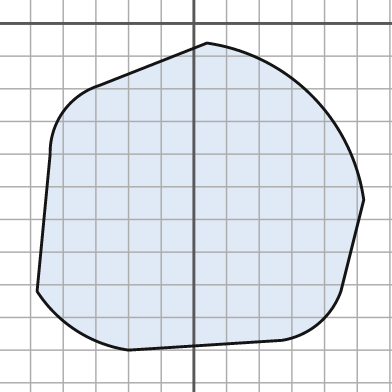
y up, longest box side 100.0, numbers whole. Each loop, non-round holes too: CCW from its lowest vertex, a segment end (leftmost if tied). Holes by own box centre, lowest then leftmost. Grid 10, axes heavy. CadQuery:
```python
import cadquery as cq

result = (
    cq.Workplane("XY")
    .moveTo(-20.0, -100.0)
    .lineTo(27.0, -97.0)
    .threePointArc((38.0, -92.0), (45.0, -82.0))
    .lineTo(52.0, -54.0)
    .threePointArc((36.0, -22.0), (4.0, -6.0))
    .lineTo(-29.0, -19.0)
    .threePointArc((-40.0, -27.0), (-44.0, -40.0))
    .lineTo(-48.0, -82.0)
    .threePointArc((-36.0, -94.0), (-20.0, -100.0))
    .close()
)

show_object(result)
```